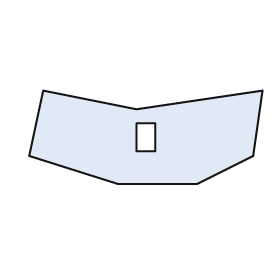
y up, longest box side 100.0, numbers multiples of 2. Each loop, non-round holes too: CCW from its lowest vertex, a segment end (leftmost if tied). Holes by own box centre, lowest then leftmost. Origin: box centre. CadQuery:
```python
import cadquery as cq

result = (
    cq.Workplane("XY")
    .moveTo(-12.0, -20.0)
    .lineTo(22.0, -20.0)
    .lineTo(46.0, -8.0)
    .lineTo(50.0, 20.0)
    .lineTo(-4.0, 12.0)
    .lineTo(-44.0, 20.0)
    .lineTo(-50.0, -8.0)
    .close()
    .moveTo(-4.0, -6.0)
    .lineTo(4.0, -6.0)
    .lineTo(4.0, 6.0)
    .lineTo(-4.0, 6.0)
    .close()
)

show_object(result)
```